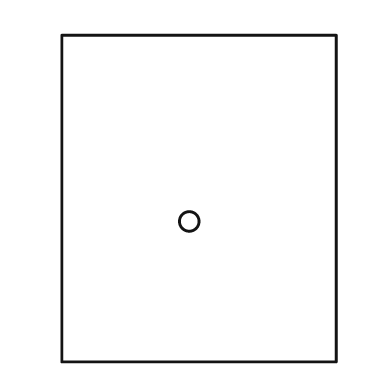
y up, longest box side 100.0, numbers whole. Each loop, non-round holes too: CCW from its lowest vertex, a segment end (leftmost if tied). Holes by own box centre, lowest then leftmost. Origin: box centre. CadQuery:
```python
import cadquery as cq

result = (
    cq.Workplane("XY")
    .moveTo(-42.0, -50.0)
    .lineTo(42.0, -50.0)
    .lineTo(42.0, 50.0)
    .lineTo(-42.0, 50.0)
    .close()
    .moveTo(-3.0, -7.0)
    .circle(3.0)
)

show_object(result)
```